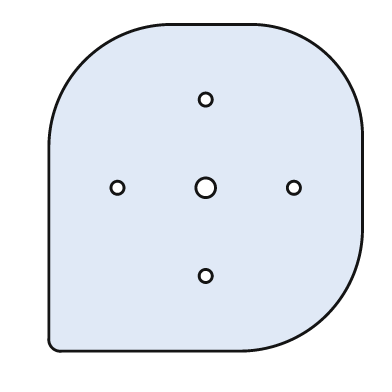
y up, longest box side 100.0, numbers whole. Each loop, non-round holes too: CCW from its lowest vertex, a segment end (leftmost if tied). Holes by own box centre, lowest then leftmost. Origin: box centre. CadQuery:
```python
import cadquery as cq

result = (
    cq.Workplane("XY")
    .moveTo(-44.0, -50.0)
    .lineTo(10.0, -50.0)
    .threePointArc((37.0, -39.0), (48.0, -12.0))
    .lineTo(48.0, 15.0)
    .threePointArc((38.0, 40.0), (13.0, 50.0))
    .lineTo(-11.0, 50.0)
    .threePointArc((-37.0, 39.0), (-48.0, 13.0))
    .lineTo(-48.0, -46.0)
    .threePointArc((-47.0, -49.0), (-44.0, -50.0))
    .close()
    .moveTo(0.0, -27.0)
    .circle(2.0)
    .moveTo(-27.0, 0.0)
    .circle(2.0)
    .moveTo(0.0, 0.0)
    .circle(3.0)
    .moveTo(27.0, 0.0)
    .circle(2.0)
    .moveTo(0.0, 27.0)
    .circle(2.0)
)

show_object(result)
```